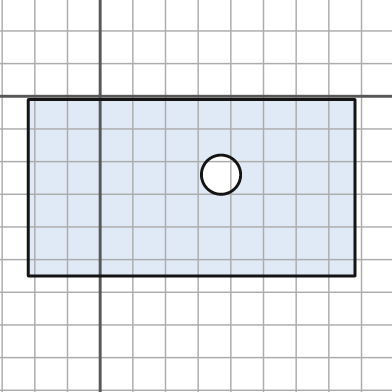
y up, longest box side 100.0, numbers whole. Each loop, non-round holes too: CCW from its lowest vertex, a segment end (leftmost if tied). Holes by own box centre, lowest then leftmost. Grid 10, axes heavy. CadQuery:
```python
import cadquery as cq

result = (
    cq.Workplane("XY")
    .moveTo(-22.0, -55.0)
    .lineTo(78.0, -55.0)
    .lineTo(78.0, -1.0)
    .lineTo(-22.0, -1.0)
    .close()
    .moveTo(37.0, -24.0)
    .circle(6.0)
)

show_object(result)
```